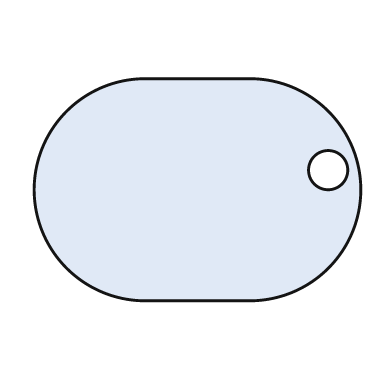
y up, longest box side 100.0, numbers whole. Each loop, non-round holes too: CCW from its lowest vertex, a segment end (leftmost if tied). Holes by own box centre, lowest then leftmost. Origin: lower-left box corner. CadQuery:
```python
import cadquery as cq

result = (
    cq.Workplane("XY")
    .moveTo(34.0, 0.0)
    .lineTo(66.0, 0.0)
    .threePointArc((100.0, 34.0), (66.0, 68.0))
    .lineTo(34.0, 68.0)
    .threePointArc((0.0, 34.0), (34.0, 0.0))
    .close()
    .moveTo(90.0, 40.0)
    .circle(6.0)
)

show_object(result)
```